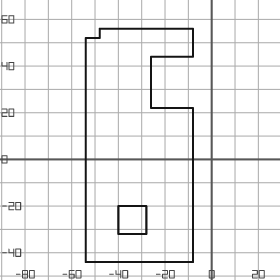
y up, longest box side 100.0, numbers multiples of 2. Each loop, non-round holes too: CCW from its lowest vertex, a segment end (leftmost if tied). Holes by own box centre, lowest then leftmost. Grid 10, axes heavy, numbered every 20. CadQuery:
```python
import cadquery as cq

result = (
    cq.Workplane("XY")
    .moveTo(-54.0, -44.0)
    .lineTo(-8.0, -44.0)
    .lineTo(-8.0, 22.0)
    .lineTo(-26.0, 22.0)
    .lineTo(-26.0, 44.0)
    .lineTo(-8.0, 44.0)
    .lineTo(-8.0, 56.0)
    .lineTo(-48.0, 56.0)
    .lineTo(-48.0, 52.0)
    .lineTo(-54.0, 52.0)
    .close()
    .moveTo(-40.0, -32.0)
    .lineTo(-28.0, -32.0)
    .lineTo(-28.0, -20.0)
    .lineTo(-40.0, -20.0)
    .close()
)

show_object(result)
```